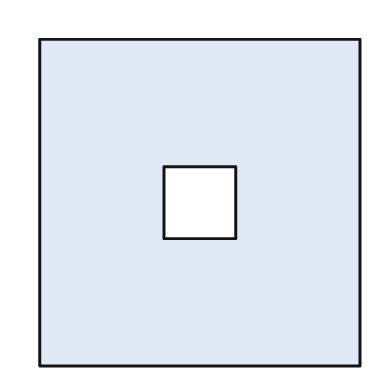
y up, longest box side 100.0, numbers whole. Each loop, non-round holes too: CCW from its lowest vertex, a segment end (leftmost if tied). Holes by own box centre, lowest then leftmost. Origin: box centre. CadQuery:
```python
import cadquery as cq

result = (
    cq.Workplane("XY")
    .moveTo(-49.0, -50.0)
    .lineTo(49.0, -50.0)
    .lineTo(49.0, 50.0)
    .lineTo(-49.0, 50.0)
    .close()
    .moveTo(-11.0, -11.0)
    .lineTo(11.0, -11.0)
    .lineTo(11.0, 11.0)
    .lineTo(-11.0, 11.0)
    .close()
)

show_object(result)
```